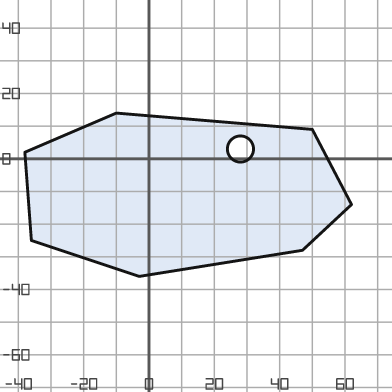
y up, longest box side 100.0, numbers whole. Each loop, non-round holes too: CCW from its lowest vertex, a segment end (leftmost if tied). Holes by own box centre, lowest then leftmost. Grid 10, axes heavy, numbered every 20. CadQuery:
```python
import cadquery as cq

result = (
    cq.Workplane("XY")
    .moveTo(-3.0, -36.0)
    .lineTo(47.0, -28.0)
    .lineTo(62.0, -14.0)
    .lineTo(50.0, 9.0)
    .lineTo(-10.0, 14.0)
    .lineTo(-38.0, 2.0)
    .lineTo(-36.0, -25.0)
    .close()
    .moveTo(28.0, 3.0)
    .circle(4.0)
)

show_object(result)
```